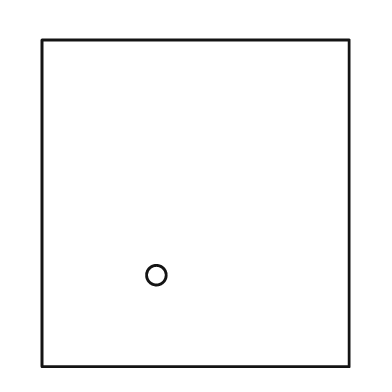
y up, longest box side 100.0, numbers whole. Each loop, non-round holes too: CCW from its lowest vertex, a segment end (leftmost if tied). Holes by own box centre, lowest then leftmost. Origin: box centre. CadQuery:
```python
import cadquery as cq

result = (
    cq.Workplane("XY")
    .moveTo(-47.0, -50.0)
    .lineTo(47.0, -50.0)
    .lineTo(47.0, 50.0)
    .lineTo(-47.0, 50.0)
    .close()
    .moveTo(-12.0, -22.0)
    .circle(3.0)
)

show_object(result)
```